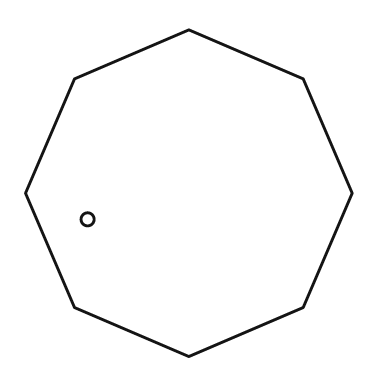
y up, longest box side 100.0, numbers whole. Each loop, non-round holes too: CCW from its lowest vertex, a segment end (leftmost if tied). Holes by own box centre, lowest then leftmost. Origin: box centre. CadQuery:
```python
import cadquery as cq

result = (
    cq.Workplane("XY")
    .moveTo(0.0, -50.0)
    .lineTo(35.0, -35.0)
    .lineTo(50.0, 0.0)
    .lineTo(35.0, 35.0)
    .lineTo(0.0, 50.0)
    .lineTo(-35.0, 35.0)
    .lineTo(-50.0, 0.0)
    .lineTo(-35.0, -35.0)
    .close()
    .moveTo(-31.0, -8.0)
    .circle(2.0)
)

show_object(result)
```